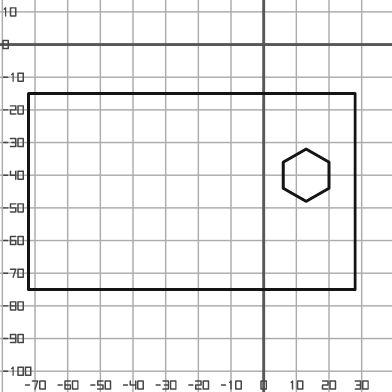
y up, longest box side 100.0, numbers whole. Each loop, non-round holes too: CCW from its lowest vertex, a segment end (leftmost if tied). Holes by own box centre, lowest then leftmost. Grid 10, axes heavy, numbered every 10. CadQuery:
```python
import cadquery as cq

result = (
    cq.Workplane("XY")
    .moveTo(-72.0, -75.0)
    .lineTo(28.0, -75.0)
    .lineTo(28.0, -15.0)
    .lineTo(-72.0, -15.0)
    .close()
    .moveTo(13.0, -48.0)
    .lineTo(20.0, -44.0)
    .lineTo(20.0, -36.0)
    .lineTo(13.0, -32.0)
    .lineTo(6.0, -36.0)
    .lineTo(6.0, -44.0)
    .close()
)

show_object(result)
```